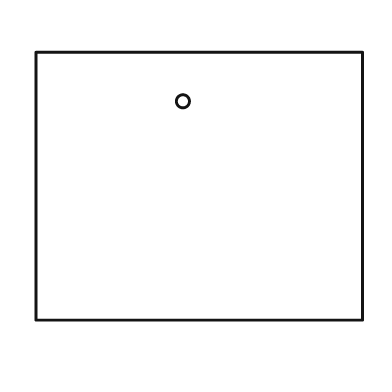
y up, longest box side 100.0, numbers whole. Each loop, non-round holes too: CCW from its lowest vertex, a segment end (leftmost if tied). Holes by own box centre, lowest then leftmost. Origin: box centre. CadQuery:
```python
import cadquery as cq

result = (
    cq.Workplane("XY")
    .moveTo(-50.0, -41.0)
    .lineTo(50.0, -41.0)
    .lineTo(50.0, 41.0)
    .lineTo(-50.0, 41.0)
    .close()
    .moveTo(-5.0, 26.0)
    .circle(2.0)
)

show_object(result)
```